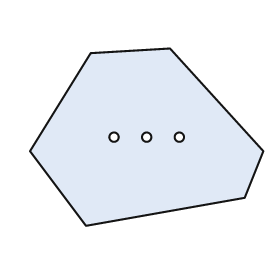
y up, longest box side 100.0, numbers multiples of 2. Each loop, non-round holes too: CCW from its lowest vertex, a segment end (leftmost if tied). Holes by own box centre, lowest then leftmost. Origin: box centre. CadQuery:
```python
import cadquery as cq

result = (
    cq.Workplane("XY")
    .moveTo(-26.0, -38.0)
    .lineTo(42.0, -26.0)
    .lineTo(50.0, -6.0)
    .lineTo(10.0, 38.0)
    .lineTo(-24.0, 36.0)
    .lineTo(-50.0, -6.0)
    .close()
    .moveTo(-14.0, 0.0)
    .circle(2.0)
    .moveTo(0.0, 0.0)
    .circle(2.0)
    .moveTo(14.0, 0.0)
    .circle(2.0)
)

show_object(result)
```